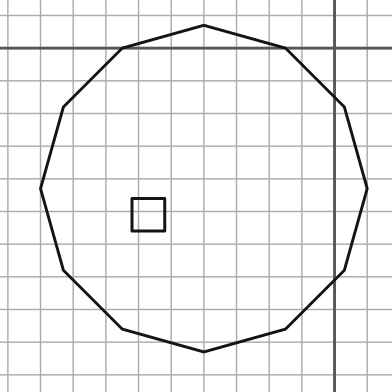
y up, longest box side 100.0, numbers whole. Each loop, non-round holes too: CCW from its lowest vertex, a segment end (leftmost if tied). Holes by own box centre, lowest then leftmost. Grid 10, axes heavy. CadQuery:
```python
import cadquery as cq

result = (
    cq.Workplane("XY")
    .moveTo(-40.0, -93.0)
    .lineTo(-15.0, -86.0)
    .lineTo(3.0, -68.0)
    .lineTo(10.0, -43.0)
    .lineTo(3.0, -18.0)
    .lineTo(-15.0, 0.0)
    .lineTo(-40.0, 7.0)
    .lineTo(-65.0, 0.0)
    .lineTo(-83.0, -18.0)
    .lineTo(-90.0, -43.0)
    .lineTo(-83.0, -68.0)
    .lineTo(-65.0, -86.0)
    .close()
    .moveTo(-62.0, -56.0)
    .lineTo(-52.0, -56.0)
    .lineTo(-52.0, -46.0)
    .lineTo(-62.0, -46.0)
    .close()
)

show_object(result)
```